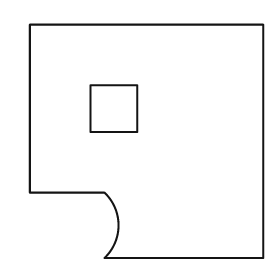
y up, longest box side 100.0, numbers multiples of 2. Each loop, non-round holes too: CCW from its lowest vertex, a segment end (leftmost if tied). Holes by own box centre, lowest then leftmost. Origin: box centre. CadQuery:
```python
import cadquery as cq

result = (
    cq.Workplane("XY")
    .moveTo(-18.0, -50.0)
    .lineTo(50.0, -50.0)
    .lineTo(50.0, 50.0)
    .lineTo(-50.0, 50.0)
    .lineTo(-50.0, -22.0)
    .lineTo(-18.0, -22.0)
    .threePointArc((-12.0, -36.0), (-18.0, -50.0))
    .close()
    .moveTo(-24.0, 4.0)
    .lineTo(-4.0, 4.0)
    .lineTo(-4.0, 24.0)
    .lineTo(-24.0, 24.0)
    .close()
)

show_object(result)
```